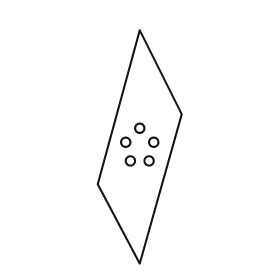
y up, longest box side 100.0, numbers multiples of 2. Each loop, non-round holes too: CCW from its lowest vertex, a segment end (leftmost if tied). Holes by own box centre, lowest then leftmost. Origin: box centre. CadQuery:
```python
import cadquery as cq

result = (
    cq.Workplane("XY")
    .moveTo(0.0, -50.0)
    .lineTo(18.0, 14.0)
    .lineTo(0.0, 50.0)
    .lineTo(-18.0, -16.0)
    .close()
    .moveTo(-4.0, -6.0)
    .circle(2.0)
    .moveTo(4.0, -6.0)
    .circle(2.0)
    .moveTo(-6.0, 2.0)
    .circle(2.0)
    .moveTo(6.0, 2.0)
    .circle(2.0)
    .moveTo(0.0, 8.0)
    .circle(2.0)
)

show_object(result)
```